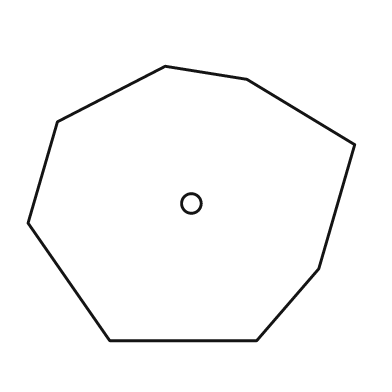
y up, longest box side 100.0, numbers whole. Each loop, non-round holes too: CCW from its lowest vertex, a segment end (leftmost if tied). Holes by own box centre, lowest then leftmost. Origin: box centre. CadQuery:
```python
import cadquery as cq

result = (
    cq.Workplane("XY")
    .moveTo(-25.0, -42.0)
    .lineTo(20.0, -42.0)
    .lineTo(39.0, -20.0)
    .lineTo(50.0, 18.0)
    .lineTo(17.0, 38.0)
    .lineTo(-8.0, 42.0)
    .lineTo(-41.0, 25.0)
    .lineTo(-50.0, -6.0)
    .close()
    .moveTo(0.0, 0.0)
    .circle(3.0)
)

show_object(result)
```